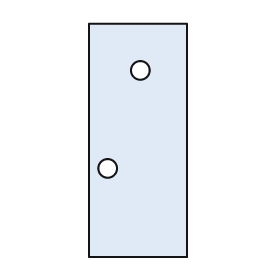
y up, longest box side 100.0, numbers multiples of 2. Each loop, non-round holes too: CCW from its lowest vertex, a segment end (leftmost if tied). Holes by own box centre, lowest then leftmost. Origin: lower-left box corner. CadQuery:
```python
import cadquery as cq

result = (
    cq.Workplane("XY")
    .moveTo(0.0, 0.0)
    .lineTo(42.0, 0.0)
    .lineTo(42.0, 100.0)
    .lineTo(0.0, 100.0)
    .close()
    .moveTo(8.0, 38.0)
    .circle(4.0)
    .moveTo(22.0, 80.0)
    .circle(4.0)
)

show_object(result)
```